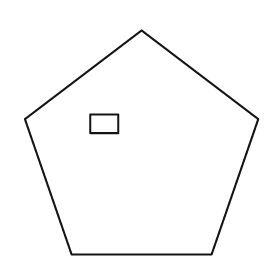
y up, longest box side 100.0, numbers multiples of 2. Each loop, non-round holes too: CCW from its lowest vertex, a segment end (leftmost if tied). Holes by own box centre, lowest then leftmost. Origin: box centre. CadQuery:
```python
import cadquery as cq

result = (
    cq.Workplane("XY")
    .moveTo(-30.0, -48.0)
    .lineTo(30.0, -48.0)
    .lineTo(50.0, 10.0)
    .lineTo(0.0, 48.0)
    .lineTo(-50.0, 10.0)
    .close()
    .moveTo(-22.0, 4.0)
    .lineTo(-10.0, 4.0)
    .lineTo(-10.0, 12.0)
    .lineTo(-22.0, 12.0)
    .close()
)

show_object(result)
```